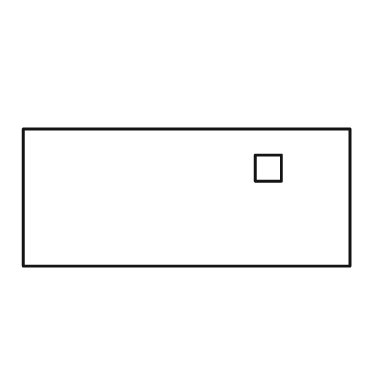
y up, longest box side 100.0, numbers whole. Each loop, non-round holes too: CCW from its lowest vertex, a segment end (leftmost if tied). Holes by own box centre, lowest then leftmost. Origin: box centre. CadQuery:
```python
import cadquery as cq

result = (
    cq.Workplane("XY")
    .moveTo(-50.0, -21.0)
    .lineTo(50.0, -21.0)
    .lineTo(50.0, 21.0)
    .lineTo(-50.0, 21.0)
    .close()
    .moveTo(21.0, 5.0)
    .lineTo(29.0, 5.0)
    .lineTo(29.0, 13.0)
    .lineTo(21.0, 13.0)
    .close()
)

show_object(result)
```